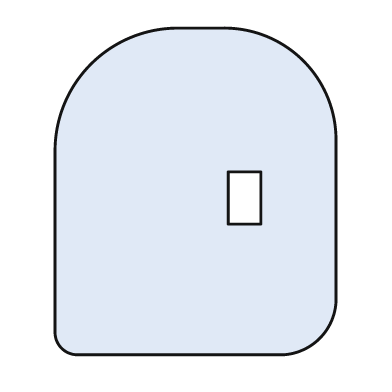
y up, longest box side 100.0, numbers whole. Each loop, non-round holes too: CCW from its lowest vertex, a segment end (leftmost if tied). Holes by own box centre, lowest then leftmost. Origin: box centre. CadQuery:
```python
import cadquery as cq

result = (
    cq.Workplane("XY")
    .moveTo(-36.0, -50.0)
    .lineTo(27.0, -50.0)
    .threePointArc((38.0, -45.0), (43.0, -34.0))
    .lineTo(43.0, 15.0)
    .threePointArc((33.0, 40.0), (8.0, 50.0))
    .lineTo(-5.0, 50.0)
    .threePointArc((-32.0, 39.0), (-43.0, 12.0))
    .lineTo(-43.0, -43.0)
    .threePointArc((-41.0, -48.0), (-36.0, -50.0))
    .close()
    .moveTo(10.0, -10.0)
    .lineTo(20.0, -10.0)
    .lineTo(20.0, 6.0)
    .lineTo(10.0, 6.0)
    .close()
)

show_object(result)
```